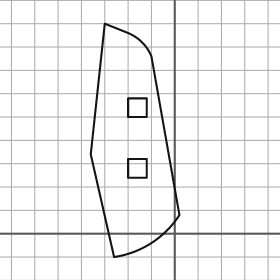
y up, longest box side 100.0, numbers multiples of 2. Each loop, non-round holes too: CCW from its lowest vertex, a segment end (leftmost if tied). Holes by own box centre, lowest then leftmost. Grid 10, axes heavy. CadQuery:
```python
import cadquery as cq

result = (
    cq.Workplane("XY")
    .moveTo(-26.0, -10.0)
    .threePointArc((-10.0, -4.0), (2.0, 8.0))
    .lineTo(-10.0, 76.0)
    .threePointArc((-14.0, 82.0), (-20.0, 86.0))
    .lineTo(-30.0, 90.0)
    .lineTo(-36.0, 34.0)
    .close()
    .moveTo(-20.0, 24.0)
    .lineTo(-12.0, 24.0)
    .lineTo(-12.0, 32.0)
    .lineTo(-20.0, 32.0)
    .close()
    .moveTo(-20.0, 50.0)
    .lineTo(-12.0, 50.0)
    .lineTo(-12.0, 58.0)
    .lineTo(-20.0, 58.0)
    .close()
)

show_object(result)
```